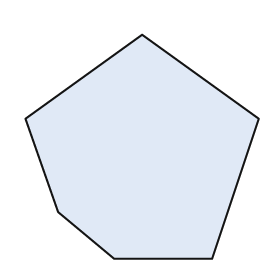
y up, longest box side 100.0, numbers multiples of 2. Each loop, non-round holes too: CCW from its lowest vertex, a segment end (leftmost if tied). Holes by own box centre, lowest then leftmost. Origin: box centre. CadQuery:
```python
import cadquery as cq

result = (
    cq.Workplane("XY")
    .moveTo(-12.0, -48.0)
    .lineTo(30.0, -48.0)
    .lineTo(50.0, 12.0)
    .lineTo(0.0, 48.0)
    .lineTo(-50.0, 12.0)
    .lineTo(-36.0, -28.0)
    .close()
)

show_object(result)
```